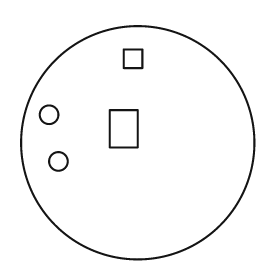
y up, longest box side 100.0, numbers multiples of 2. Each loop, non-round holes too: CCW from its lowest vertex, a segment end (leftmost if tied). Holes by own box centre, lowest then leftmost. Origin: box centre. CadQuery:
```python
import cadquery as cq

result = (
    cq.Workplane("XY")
    .moveTo(0.0, 0.0)
    .circle(50.0)
    .moveTo(-34.0, -8.0)
    .circle(4.0)
    .moveTo(-12.0, -2.0)
    .lineTo(0.0, -2.0)
    .lineTo(0.0, 14.0)
    .lineTo(-12.0, 14.0)
    .close()
    .moveTo(-38.0, 12.0)
    .circle(4.0)
    .moveTo(-6.0, 32.0)
    .lineTo(2.0, 32.0)
    .lineTo(2.0, 40.0)
    .lineTo(-6.0, 40.0)
    .close()
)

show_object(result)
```